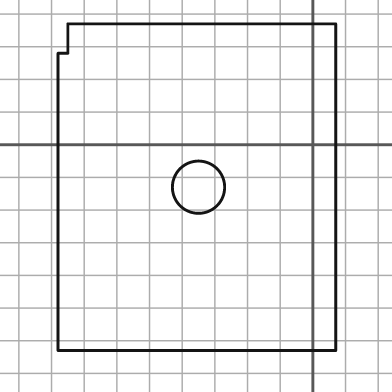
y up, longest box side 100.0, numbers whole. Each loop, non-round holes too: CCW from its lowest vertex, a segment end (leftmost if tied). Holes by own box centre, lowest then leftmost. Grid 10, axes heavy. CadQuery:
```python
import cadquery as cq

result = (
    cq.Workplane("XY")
    .moveTo(-78.0, -63.0)
    .lineTo(7.0, -63.0)
    .lineTo(7.0, 37.0)
    .lineTo(-75.0, 37.0)
    .lineTo(-75.0, 28.0)
    .lineTo(-78.0, 28.0)
    .close()
    .moveTo(-35.0, -13.0)
    .circle(8.0)
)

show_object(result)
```